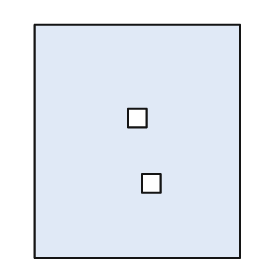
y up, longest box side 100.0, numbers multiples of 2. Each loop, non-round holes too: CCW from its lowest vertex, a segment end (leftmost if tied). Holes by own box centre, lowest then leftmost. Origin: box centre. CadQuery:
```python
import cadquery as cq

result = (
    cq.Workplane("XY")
    .moveTo(-44.0, -50.0)
    .lineTo(44.0, -50.0)
    .lineTo(44.0, 50.0)
    .lineTo(-44.0, 50.0)
    .close()
    .moveTo(2.0, -22.0)
    .lineTo(10.0, -22.0)
    .lineTo(10.0, -14.0)
    .lineTo(2.0, -14.0)
    .close()
    .moveTo(-4.0, 6.0)
    .lineTo(4.0, 6.0)
    .lineTo(4.0, 14.0)
    .lineTo(-4.0, 14.0)
    .close()
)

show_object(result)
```